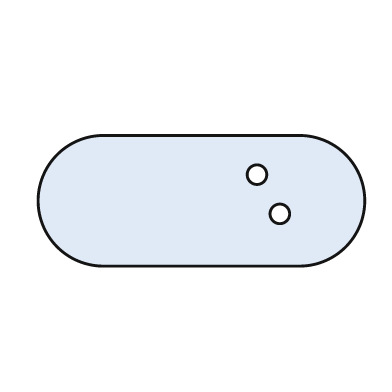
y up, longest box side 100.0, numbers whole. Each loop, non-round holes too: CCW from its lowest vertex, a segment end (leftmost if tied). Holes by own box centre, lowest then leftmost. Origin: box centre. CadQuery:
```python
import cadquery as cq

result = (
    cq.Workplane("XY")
    .moveTo(-30.0, -20.0)
    .lineTo(30.0, -20.0)
    .threePointArc((50.0, 0.0), (30.0, 20.0))
    .lineTo(-30.0, 20.0)
    .threePointArc((-50.0, 0.0), (-30.0, -20.0))
    .close()
    .moveTo(24.0, -4.0)
    .circle(3.0)
    .moveTo(17.0, 8.0)
    .circle(3.0)
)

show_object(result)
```